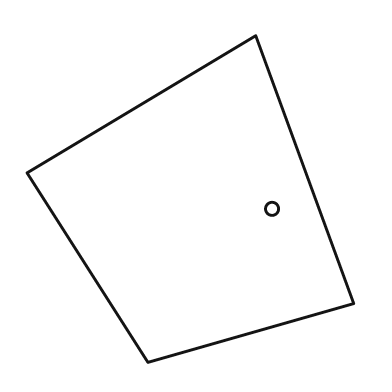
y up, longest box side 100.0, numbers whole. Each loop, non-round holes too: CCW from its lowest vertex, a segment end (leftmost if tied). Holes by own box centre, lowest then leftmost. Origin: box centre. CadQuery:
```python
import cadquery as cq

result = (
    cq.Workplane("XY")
    .moveTo(-13.0, -50.0)
    .lineTo(50.0, -32.0)
    .lineTo(20.0, 50.0)
    .lineTo(-50.0, 8.0)
    .close()
    .moveTo(25.0, -3.0)
    .circle(2.0)
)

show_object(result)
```